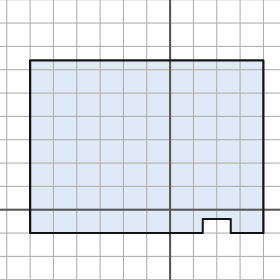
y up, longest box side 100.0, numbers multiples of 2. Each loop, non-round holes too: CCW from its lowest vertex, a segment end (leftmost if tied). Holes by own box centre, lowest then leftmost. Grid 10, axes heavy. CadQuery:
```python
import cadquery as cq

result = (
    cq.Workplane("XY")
    .moveTo(-60.0, -10.0)
    .lineTo(14.0, -10.0)
    .lineTo(14.0, -4.0)
    .lineTo(26.0, -4.0)
    .lineTo(26.0, -10.0)
    .lineTo(40.0, -10.0)
    .lineTo(40.0, 64.0)
    .lineTo(-60.0, 64.0)
    .close()
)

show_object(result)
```